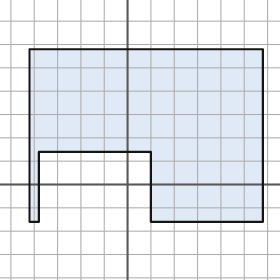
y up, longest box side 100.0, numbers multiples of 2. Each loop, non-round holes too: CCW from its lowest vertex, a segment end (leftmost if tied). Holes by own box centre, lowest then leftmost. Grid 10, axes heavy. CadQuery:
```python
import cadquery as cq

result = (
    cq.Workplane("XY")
    .moveTo(-42.0, -16.0)
    .lineTo(-38.0, -16.0)
    .lineTo(-38.0, 14.0)
    .lineTo(10.0, 14.0)
    .lineTo(10.0, -16.0)
    .lineTo(58.0, -16.0)
    .lineTo(58.0, 58.0)
    .lineTo(-42.0, 58.0)
    .close()
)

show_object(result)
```